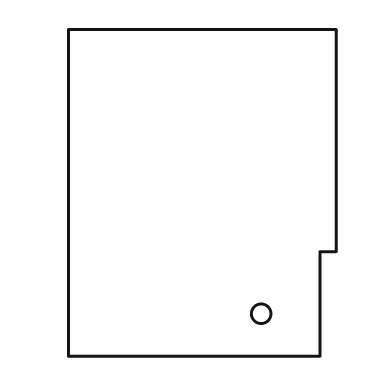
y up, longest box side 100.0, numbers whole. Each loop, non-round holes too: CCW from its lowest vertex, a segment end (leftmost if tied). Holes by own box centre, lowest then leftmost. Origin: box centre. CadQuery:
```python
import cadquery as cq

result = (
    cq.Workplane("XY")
    .moveTo(-41.0, -50.0)
    .lineTo(36.0, -50.0)
    .lineTo(36.0, -18.0)
    .lineTo(41.0, -18.0)
    .lineTo(41.0, 50.0)
    .lineTo(-41.0, 50.0)
    .close()
    .moveTo(18.0, -37.0)
    .circle(3.0)
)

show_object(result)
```